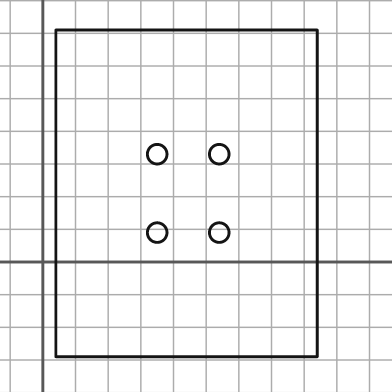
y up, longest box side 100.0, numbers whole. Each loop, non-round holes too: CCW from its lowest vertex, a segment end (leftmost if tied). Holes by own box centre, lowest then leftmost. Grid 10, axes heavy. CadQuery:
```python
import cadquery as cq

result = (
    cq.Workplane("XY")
    .moveTo(4.0, -29.0)
    .lineTo(84.0, -29.0)
    .lineTo(84.0, 71.0)
    .lineTo(4.0, 71.0)
    .close()
    .moveTo(35.0, 9.0)
    .circle(3.0)
    .moveTo(54.0, 9.0)
    .circle(3.0)
    .moveTo(35.0, 33.0)
    .circle(3.0)
    .moveTo(54.0, 33.0)
    .circle(3.0)
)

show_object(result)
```